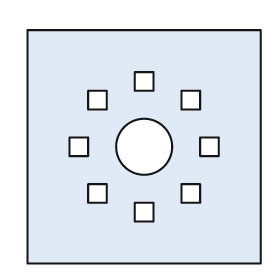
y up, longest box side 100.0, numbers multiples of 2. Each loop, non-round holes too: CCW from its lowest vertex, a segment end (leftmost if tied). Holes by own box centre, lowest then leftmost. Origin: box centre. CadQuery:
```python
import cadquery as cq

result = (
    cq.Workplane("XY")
    .moveTo(-50.0, -50.0)
    .lineTo(50.0, -50.0)
    .lineTo(50.0, 50.0)
    .lineTo(-50.0, 50.0)
    .close()
    .moveTo(-4.0, -32.0)
    .lineTo(4.0, -32.0)
    .lineTo(4.0, -24.0)
    .lineTo(-4.0, -24.0)
    .close()
    .moveTo(-24.0, -24.0)
    .lineTo(-16.0, -24.0)
    .lineTo(-16.0, -16.0)
    .lineTo(-24.0, -16.0)
    .close()
    .moveTo(16.0, -24.0)
    .lineTo(24.0, -24.0)
    .lineTo(24.0, -16.0)
    .lineTo(16.0, -16.0)
    .close()
    .moveTo(-32.0, -4.0)
    .lineTo(-24.0, -4.0)
    .lineTo(-24.0, 4.0)
    .lineTo(-32.0, 4.0)
    .close()
    .moveTo(0.0, 0.0)
    .circle(12.0)
    .moveTo(24.0, -4.0)
    .lineTo(32.0, -4.0)
    .lineTo(32.0, 4.0)
    .lineTo(24.0, 4.0)
    .close()
    .moveTo(-24.0, 16.0)
    .lineTo(-16.0, 16.0)
    .lineTo(-16.0, 24.0)
    .lineTo(-24.0, 24.0)
    .close()
    .moveTo(16.0, 16.0)
    .lineTo(24.0, 16.0)
    .lineTo(24.0, 24.0)
    .lineTo(16.0, 24.0)
    .close()
    .moveTo(-4.0, 24.0)
    .lineTo(4.0, 24.0)
    .lineTo(4.0, 32.0)
    .lineTo(-4.0, 32.0)
    .close()
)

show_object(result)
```